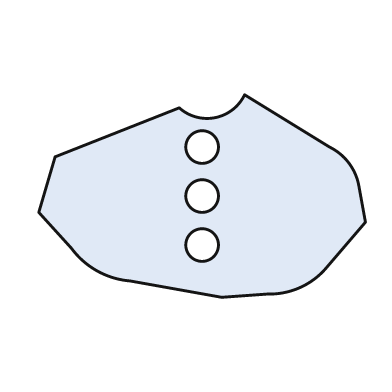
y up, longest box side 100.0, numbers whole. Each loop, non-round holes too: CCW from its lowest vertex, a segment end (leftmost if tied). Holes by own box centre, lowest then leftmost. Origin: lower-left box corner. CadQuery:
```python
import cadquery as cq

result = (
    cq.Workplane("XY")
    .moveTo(56.0, 0.0)
    .lineTo(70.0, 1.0)
    .threePointArc((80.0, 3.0), (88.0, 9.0))
    .lineTo(100.0, 23.0)
    .lineTo(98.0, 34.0)
    .threePointArc((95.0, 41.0), (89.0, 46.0))
    .lineTo(63.0, 62.0)
    .threePointArc((54.0, 55.0), (43.0, 58.0))
    .lineTo(5.0, 43.0)
    .lineTo(0.0, 26.0)
    .lineTo(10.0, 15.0)
    .threePointArc((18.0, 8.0), (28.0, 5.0))
    .close()
    .moveTo(50.0, 16.0)
    .circle(5.0)
    .moveTo(50.0, 31.0)
    .circle(5.0)
    .moveTo(50.0, 46.0)
    .circle(5.0)
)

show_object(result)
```